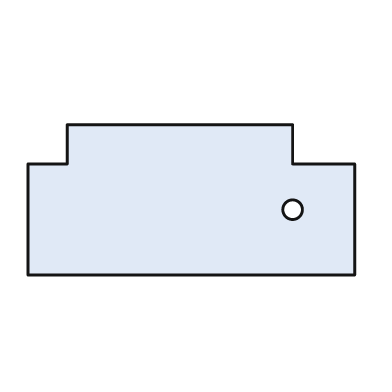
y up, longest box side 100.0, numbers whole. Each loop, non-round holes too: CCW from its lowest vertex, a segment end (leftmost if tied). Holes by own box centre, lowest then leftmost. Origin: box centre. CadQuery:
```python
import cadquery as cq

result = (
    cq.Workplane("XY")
    .moveTo(-50.0, -23.0)
    .lineTo(50.0, -23.0)
    .lineTo(50.0, 11.0)
    .lineTo(31.0, 11.0)
    .lineTo(31.0, 23.0)
    .lineTo(-38.0, 23.0)
    .lineTo(-38.0, 11.0)
    .lineTo(-50.0, 11.0)
    .close()
    .moveTo(31.0, -3.0)
    .circle(3.0)
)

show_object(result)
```